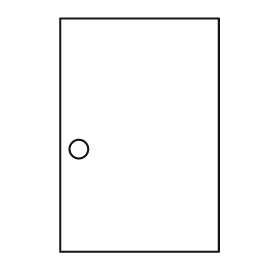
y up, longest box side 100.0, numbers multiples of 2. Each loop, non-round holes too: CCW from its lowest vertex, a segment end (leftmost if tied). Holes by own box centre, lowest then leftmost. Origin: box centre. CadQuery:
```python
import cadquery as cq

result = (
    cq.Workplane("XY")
    .moveTo(-34.0, -50.0)
    .lineTo(34.0, -50.0)
    .lineTo(34.0, 50.0)
    .lineTo(-34.0, 50.0)
    .close()
    .moveTo(-26.0, -6.0)
    .circle(4.0)
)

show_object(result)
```